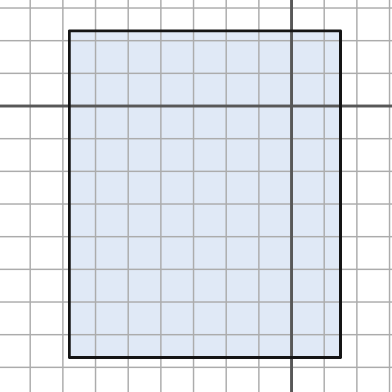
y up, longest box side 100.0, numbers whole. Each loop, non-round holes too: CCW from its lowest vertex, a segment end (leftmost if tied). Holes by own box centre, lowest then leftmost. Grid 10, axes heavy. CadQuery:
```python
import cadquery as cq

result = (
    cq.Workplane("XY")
    .moveTo(-68.0, -77.0)
    .lineTo(15.0, -77.0)
    .lineTo(15.0, 23.0)
    .lineTo(-68.0, 23.0)
    .close()
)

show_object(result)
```